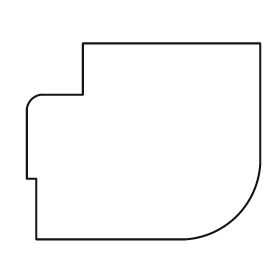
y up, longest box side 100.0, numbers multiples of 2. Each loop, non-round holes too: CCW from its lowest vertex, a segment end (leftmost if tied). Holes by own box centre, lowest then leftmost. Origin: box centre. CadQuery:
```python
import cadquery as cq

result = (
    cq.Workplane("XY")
    .moveTo(-46.0, -42.0)
    .lineTo(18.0, -42.0)
    .threePointArc((40.0, -32.0), (50.0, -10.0))
    .lineTo(50.0, 42.0)
    .lineTo(-26.0, 42.0)
    .lineTo(-26.0, 20.0)
    .lineTo(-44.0, 20.0)
    .threePointArc((-48.0, 18.0), (-50.0, 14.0))
    .lineTo(-50.0, -16.0)
    .lineTo(-46.0, -16.0)
    .close()
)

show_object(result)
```